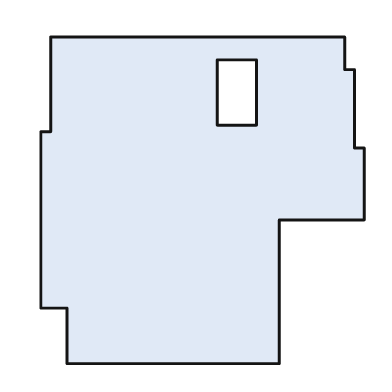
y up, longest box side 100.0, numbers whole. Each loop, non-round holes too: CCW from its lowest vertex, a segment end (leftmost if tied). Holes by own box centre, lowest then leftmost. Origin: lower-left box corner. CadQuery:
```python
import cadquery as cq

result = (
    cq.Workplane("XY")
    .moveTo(8.0, 0.0)
    .lineTo(73.0, 0.0)
    .lineTo(73.0, 44.0)
    .lineTo(99.0, 44.0)
    .lineTo(99.0, 66.0)
    .lineTo(96.0, 66.0)
    .lineTo(96.0, 90.0)
    .lineTo(93.0, 90.0)
    .lineTo(93.0, 100.0)
    .lineTo(3.0, 100.0)
    .lineTo(3.0, 71.0)
    .lineTo(0.0, 71.0)
    .lineTo(0.0, 17.0)
    .lineTo(8.0, 17.0)
    .close()
    .moveTo(54.0, 73.0)
    .lineTo(66.0, 73.0)
    .lineTo(66.0, 93.0)
    .lineTo(54.0, 93.0)
    .close()
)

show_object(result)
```